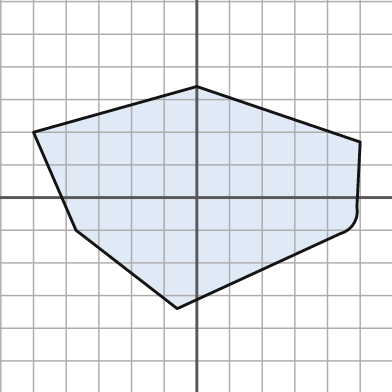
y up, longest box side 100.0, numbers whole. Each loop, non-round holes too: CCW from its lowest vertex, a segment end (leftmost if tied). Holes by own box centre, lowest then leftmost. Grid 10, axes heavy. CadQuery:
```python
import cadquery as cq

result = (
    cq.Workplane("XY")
    .moveTo(-6.0, -34.0)
    .lineTo(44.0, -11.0)
    .threePointArc((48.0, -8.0), (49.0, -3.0))
    .lineTo(50.0, 17.0)
    .lineTo(0.0, 34.0)
    .lineTo(-50.0, 20.0)
    .lineTo(-37.0, -10.0)
    .close()
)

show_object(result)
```